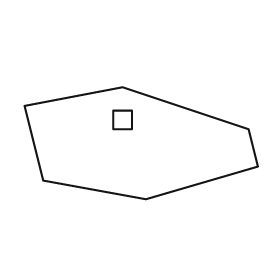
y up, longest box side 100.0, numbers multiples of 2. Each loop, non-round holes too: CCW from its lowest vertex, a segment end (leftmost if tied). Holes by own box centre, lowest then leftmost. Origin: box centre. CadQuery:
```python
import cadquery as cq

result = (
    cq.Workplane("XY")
    .moveTo(2.0, -24.0)
    .lineTo(50.0, -10.0)
    .lineTo(46.0, 6.0)
    .lineTo(-8.0, 24.0)
    .lineTo(-50.0, 16.0)
    .lineTo(-42.0, -16.0)
    .close()
    .moveTo(-12.0, 6.0)
    .lineTo(-4.0, 6.0)
    .lineTo(-4.0, 14.0)
    .lineTo(-12.0, 14.0)
    .close()
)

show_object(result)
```